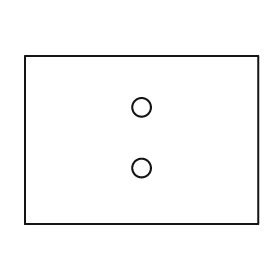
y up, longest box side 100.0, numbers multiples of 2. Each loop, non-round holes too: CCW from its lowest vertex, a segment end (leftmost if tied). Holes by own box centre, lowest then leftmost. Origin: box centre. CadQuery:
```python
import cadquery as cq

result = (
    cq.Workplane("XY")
    .moveTo(-50.0, -36.0)
    .lineTo(50.0, -36.0)
    .lineTo(50.0, 36.0)
    .lineTo(-50.0, 36.0)
    .close()
    .moveTo(0.0, -12.0)
    .circle(4.0)
    .moveTo(0.0, 14.0)
    .circle(4.0)
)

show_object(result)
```